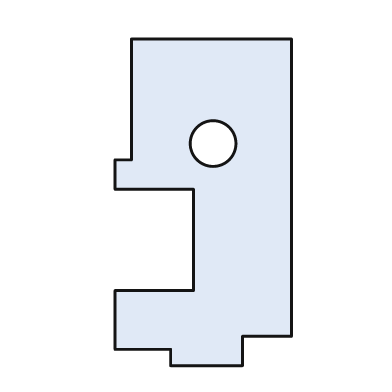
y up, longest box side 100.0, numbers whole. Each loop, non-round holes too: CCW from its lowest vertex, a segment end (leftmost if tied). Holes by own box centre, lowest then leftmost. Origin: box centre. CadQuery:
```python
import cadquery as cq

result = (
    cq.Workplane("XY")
    .moveTo(-10.0, -50.0)
    .lineTo(12.0, -50.0)
    .lineTo(12.0, -41.0)
    .lineTo(27.0, -41.0)
    .lineTo(27.0, 50.0)
    .lineTo(-22.0, 50.0)
    .lineTo(-22.0, 13.0)
    .lineTo(-27.0, 13.0)
    .lineTo(-27.0, 4.0)
    .lineTo(-3.0, 4.0)
    .lineTo(-3.0, -27.0)
    .lineTo(-27.0, -27.0)
    .lineTo(-27.0, -45.0)
    .lineTo(-10.0, -45.0)
    .close()
    .moveTo(3.0, 18.0)
    .circle(7.0)
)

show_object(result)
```